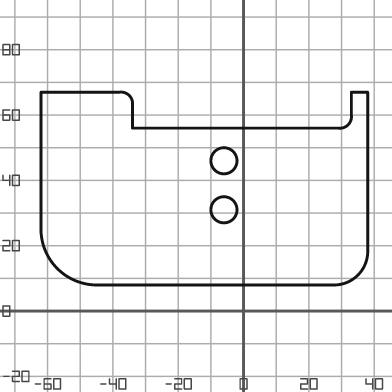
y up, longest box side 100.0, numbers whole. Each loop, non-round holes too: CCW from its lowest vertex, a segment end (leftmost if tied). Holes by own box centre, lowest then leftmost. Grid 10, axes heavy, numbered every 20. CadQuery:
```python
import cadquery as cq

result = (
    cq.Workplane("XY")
    .moveTo(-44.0, 8.0)
    .lineTo(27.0, 8.0)
    .threePointArc((35.0, 11.0), (38.0, 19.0))
    .lineTo(38.0, 67.0)
    .lineTo(33.0, 67.0)
    .lineTo(33.0, 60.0)
    .threePointArc((32.0, 57.0), (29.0, 56.0))
    .lineTo(-34.0, 56.0)
    .lineTo(-34.0, 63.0)
    .threePointArc((-35.0, 66.0), (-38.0, 67.0))
    .lineTo(-62.0, 67.0)
    .lineTo(-62.0, 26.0)
    .threePointArc((-57.0, 13.0), (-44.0, 8.0))
    .close()
    .moveTo(-6.0, 31.0)
    .circle(4.0)
    .moveTo(-6.0, 46.0)
    .circle(4.0)
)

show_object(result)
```